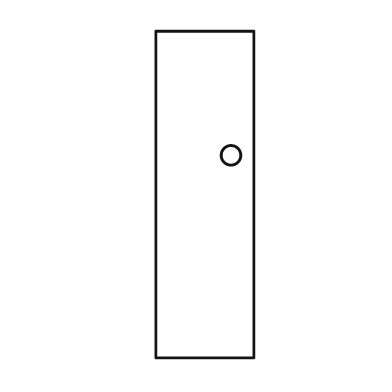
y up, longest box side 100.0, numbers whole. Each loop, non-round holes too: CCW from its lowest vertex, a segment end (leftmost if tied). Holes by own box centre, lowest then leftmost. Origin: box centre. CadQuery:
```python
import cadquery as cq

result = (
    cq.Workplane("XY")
    .moveTo(-15.0, -50.0)
    .lineTo(15.0, -50.0)
    .lineTo(15.0, 50.0)
    .lineTo(-15.0, 50.0)
    .close()
    .moveTo(8.0, 12.0)
    .circle(3.0)
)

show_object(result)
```